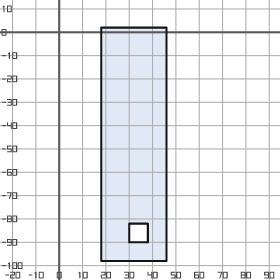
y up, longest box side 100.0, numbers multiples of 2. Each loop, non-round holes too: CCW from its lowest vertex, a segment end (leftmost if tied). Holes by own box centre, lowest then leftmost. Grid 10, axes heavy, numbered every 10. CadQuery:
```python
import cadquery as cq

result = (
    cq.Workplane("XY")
    .moveTo(18.0, -98.0)
    .lineTo(46.0, -98.0)
    .lineTo(46.0, 2.0)
    .lineTo(18.0, 2.0)
    .close()
    .moveTo(30.0, -90.0)
    .lineTo(38.0, -90.0)
    .lineTo(38.0, -82.0)
    .lineTo(30.0, -82.0)
    .close()
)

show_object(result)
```